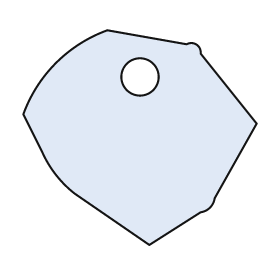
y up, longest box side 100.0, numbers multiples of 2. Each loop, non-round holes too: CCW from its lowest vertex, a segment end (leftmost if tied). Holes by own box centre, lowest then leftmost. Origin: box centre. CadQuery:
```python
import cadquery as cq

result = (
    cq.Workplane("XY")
    .moveTo(4.0, -46.0)
    .lineTo(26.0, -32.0)
    .threePointArc((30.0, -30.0), (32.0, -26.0))
    .lineTo(50.0, 6.0)
    .lineTo(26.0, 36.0)
    .threePointArc((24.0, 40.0), (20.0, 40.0))
    .lineTo(-14.0, 46.0)
    .threePointArc((-36.0, 32.0), (-50.0, 10.0))
    .lineTo(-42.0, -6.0)
    .threePointArc((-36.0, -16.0), (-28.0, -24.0))
    .close()
    .moveTo(0.0, 26.0)
    .circle(8.0)
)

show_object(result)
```